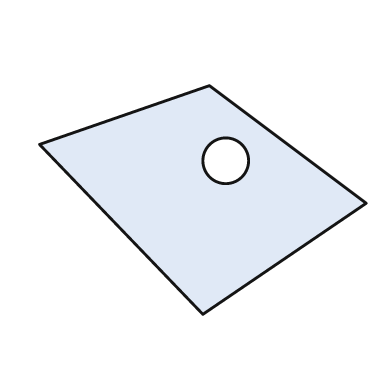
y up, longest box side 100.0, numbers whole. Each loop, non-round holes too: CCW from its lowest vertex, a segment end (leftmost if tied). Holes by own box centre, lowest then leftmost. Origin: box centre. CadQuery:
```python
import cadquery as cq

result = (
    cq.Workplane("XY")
    .moveTo(0.0, -35.0)
    .lineTo(50.0, -1.0)
    .lineTo(2.0, 35.0)
    .lineTo(-50.0, 17.0)
    .close()
    .moveTo(7.0, 12.0)
    .circle(7.0)
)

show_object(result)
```